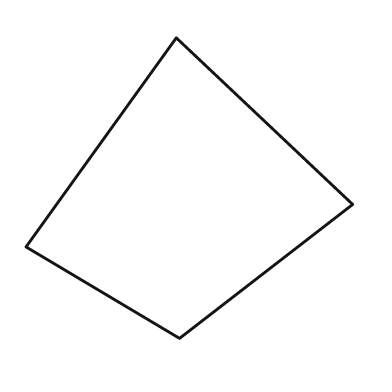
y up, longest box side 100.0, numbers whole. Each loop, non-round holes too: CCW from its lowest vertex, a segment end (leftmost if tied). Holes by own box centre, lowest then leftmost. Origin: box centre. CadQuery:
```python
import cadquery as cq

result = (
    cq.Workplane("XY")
    .moveTo(-3.0, -46.0)
    .lineTo(50.0, -5.0)
    .lineTo(-4.0, 46.0)
    .lineTo(-50.0, -18.0)
    .close()
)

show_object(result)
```